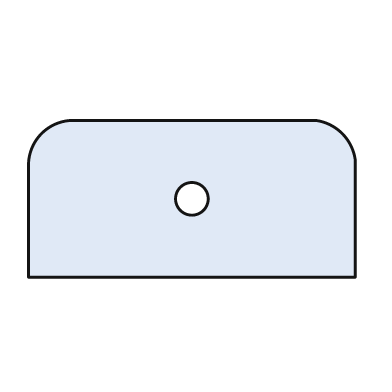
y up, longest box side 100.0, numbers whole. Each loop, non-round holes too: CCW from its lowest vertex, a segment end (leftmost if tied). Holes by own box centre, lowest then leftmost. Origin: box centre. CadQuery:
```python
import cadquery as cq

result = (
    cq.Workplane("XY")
    .moveTo(-50.0, -24.0)
    .lineTo(50.0, -24.0)
    .lineTo(50.0, 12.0)
    .threePointArc((46.0, 20.0), (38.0, 24.0))
    .lineTo(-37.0, 24.0)
    .threePointArc((-46.0, 20.0), (-50.0, 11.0))
    .close()
    .moveTo(0.0, 0.0)
    .circle(5.0)
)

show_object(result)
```